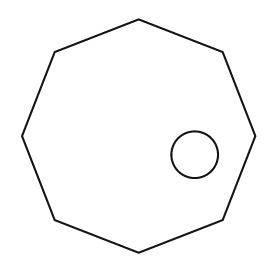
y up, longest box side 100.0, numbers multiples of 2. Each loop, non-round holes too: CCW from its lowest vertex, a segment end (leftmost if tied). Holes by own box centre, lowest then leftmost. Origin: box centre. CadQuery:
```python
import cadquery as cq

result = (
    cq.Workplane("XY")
    .moveTo(0.0, -50.0)
    .lineTo(36.0, -36.0)
    .lineTo(50.0, 0.0)
    .lineTo(36.0, 36.0)
    .lineTo(0.0, 50.0)
    .lineTo(-36.0, 36.0)
    .lineTo(-50.0, 0.0)
    .lineTo(-36.0, -36.0)
    .close()
    .moveTo(24.0, -8.0)
    .circle(10.0)
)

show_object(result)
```